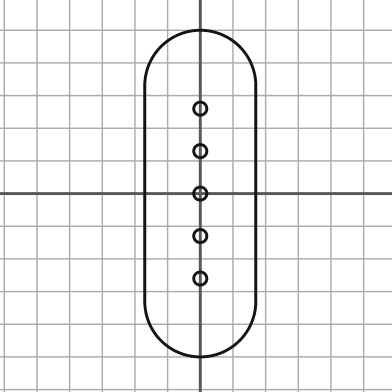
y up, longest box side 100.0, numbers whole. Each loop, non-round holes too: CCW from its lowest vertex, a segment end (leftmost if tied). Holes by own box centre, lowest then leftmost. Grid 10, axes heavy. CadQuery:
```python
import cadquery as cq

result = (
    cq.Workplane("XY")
    .moveTo(-17.0, -33.0)
    .threePointArc((0.0, -50.0), (17.0, -33.0))
    .lineTo(17.0, 33.0)
    .threePointArc((0.0, 50.0), (-17.0, 33.0))
    .close()
    .moveTo(0.0, -26.0)
    .circle(2.0)
    .moveTo(0.0, -13.0)
    .circle(2.0)
    .moveTo(0.0, 0.0)
    .circle(2.0)
    .moveTo(0.0, 13.0)
    .circle(2.0)
    .moveTo(0.0, 26.0)
    .circle(2.0)
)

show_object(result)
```